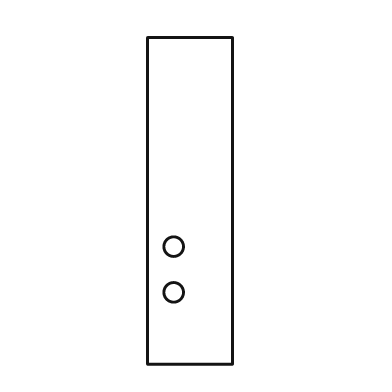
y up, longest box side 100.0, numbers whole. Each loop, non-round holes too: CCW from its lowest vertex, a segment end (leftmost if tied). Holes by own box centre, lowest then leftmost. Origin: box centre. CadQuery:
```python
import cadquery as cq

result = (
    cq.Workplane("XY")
    .moveTo(-13.0, -50.0)
    .lineTo(13.0, -50.0)
    .lineTo(13.0, 50.0)
    .lineTo(-13.0, 50.0)
    .close()
    .moveTo(-5.0, -28.0)
    .circle(3.0)
    .moveTo(-5.0, -14.0)
    .circle(3.0)
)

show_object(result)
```